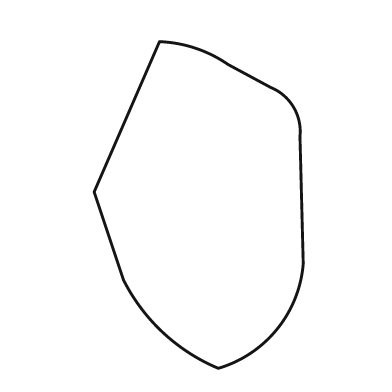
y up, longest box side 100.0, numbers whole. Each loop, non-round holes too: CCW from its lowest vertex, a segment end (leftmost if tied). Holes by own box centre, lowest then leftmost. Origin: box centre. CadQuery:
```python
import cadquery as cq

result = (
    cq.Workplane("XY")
    .moveTo(6.0, -50.0)
    .threePointArc((24.0, -38.0), (32.0, -18.0))
    .lineTo(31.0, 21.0)
    .threePointArc((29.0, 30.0), (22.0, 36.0))
    .lineTo(9.0, 43.0)
    .threePointArc((-1.0, 48.0), (-12.0, 50.0))
    .lineTo(-32.0, 4.0)
    .lineTo(-23.0, -23.0)
    .threePointArc((-11.0, -39.0), (6.0, -50.0))
    .close()
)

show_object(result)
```